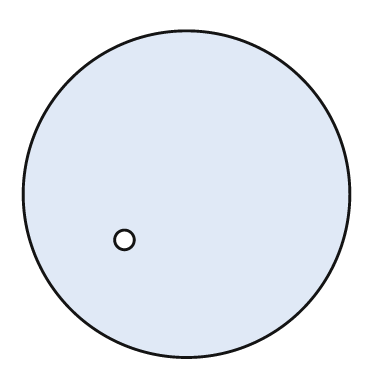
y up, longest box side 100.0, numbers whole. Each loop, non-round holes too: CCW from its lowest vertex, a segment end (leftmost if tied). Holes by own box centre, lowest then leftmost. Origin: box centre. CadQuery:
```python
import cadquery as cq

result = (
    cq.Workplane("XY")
    .moveTo(0.0, 0.0)
    .circle(50.0)
    .moveTo(-19.0, -14.0)
    .circle(3.0)
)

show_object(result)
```